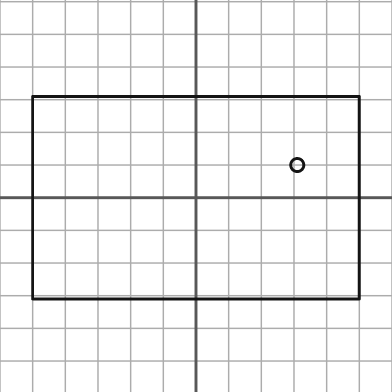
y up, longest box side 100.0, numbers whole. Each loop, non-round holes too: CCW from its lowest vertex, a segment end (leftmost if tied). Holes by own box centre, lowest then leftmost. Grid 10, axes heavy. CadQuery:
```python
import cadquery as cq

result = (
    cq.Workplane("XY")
    .moveTo(-50.0, -31.0)
    .lineTo(50.0, -31.0)
    .lineTo(50.0, 31.0)
    .lineTo(-50.0, 31.0)
    .close()
    .moveTo(31.0, 10.0)
    .circle(2.0)
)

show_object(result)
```